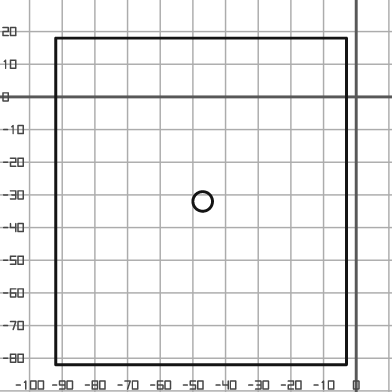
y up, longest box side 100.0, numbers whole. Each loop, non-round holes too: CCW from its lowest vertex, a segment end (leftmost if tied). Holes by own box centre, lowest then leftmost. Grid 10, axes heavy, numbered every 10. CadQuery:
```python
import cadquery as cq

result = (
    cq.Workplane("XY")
    .moveTo(-92.0, -82.0)
    .lineTo(-3.0, -82.0)
    .lineTo(-3.0, 18.0)
    .lineTo(-92.0, 18.0)
    .close()
    .moveTo(-47.0, -32.0)
    .circle(3.0)
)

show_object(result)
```